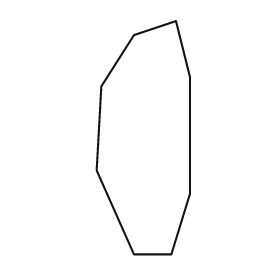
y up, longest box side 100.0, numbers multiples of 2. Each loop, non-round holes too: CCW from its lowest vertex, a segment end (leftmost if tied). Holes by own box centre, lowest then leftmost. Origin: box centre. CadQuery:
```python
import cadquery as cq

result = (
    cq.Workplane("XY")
    .moveTo(-4.0, -50.0)
    .lineTo(12.0, -50.0)
    .lineTo(20.0, -24.0)
    .lineTo(20.0, 26.0)
    .lineTo(14.0, 50.0)
    .lineTo(-4.0, 44.0)
    .lineTo(-18.0, 22.0)
    .lineTo(-20.0, -14.0)
    .close()
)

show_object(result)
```